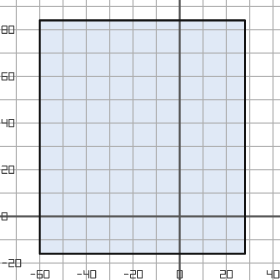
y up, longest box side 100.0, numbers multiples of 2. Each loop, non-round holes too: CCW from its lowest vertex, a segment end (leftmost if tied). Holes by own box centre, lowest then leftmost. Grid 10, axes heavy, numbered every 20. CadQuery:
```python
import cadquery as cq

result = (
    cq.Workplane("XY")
    .moveTo(-60.0, -16.0)
    .lineTo(28.0, -16.0)
    .lineTo(28.0, 84.0)
    .lineTo(-60.0, 84.0)
    .close()
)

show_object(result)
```